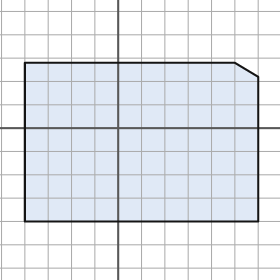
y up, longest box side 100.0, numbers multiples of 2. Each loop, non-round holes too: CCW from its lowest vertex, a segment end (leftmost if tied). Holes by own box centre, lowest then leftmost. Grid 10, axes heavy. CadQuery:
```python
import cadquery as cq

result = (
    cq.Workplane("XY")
    .moveTo(-40.0, -40.0)
    .lineTo(60.0, -40.0)
    .lineTo(60.0, 22.0)
    .lineTo(50.0, 28.0)
    .lineTo(-40.0, 28.0)
    .close()
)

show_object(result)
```